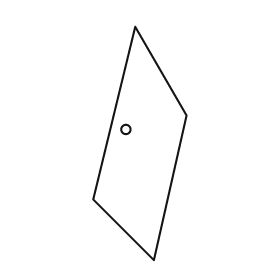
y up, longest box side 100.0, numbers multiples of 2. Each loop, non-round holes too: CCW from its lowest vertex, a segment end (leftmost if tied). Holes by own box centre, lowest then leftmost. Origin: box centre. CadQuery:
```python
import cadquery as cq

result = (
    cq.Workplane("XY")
    .moveTo(6.0, -50.0)
    .lineTo(20.0, 12.0)
    .lineTo(-2.0, 50.0)
    .lineTo(-20.0, -24.0)
    .close()
    .moveTo(-6.0, 6.0)
    .circle(2.0)
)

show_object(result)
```